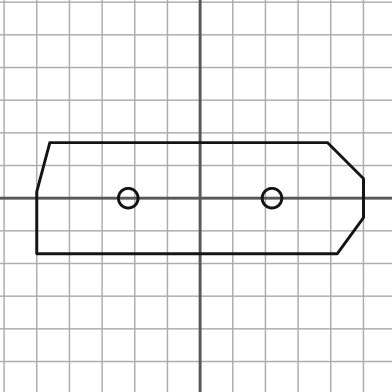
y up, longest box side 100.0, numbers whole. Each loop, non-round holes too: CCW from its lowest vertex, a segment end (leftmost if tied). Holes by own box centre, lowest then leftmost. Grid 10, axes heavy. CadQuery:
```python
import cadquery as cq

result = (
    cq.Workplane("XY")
    .moveTo(-50.0, -17.0)
    .lineTo(42.0, -17.0)
    .lineTo(50.0, -6.0)
    .lineTo(50.0, 6.0)
    .lineTo(39.0, 17.0)
    .lineTo(-46.0, 17.0)
    .lineTo(-50.0, 2.0)
    .close()
    .moveTo(-22.0, 0.0)
    .circle(3.0)
    .moveTo(22.0, 0.0)
    .circle(3.0)
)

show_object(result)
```